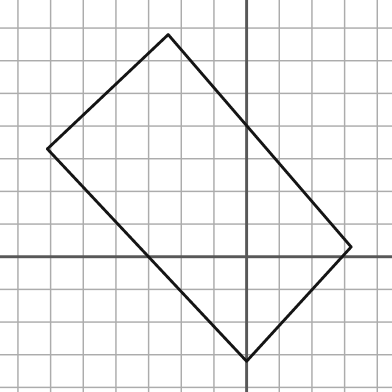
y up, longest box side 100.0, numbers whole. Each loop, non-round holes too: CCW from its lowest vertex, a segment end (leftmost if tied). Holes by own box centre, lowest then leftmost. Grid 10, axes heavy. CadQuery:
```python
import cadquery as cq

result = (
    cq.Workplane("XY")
    .moveTo(0.0, -32.0)
    .lineTo(32.0, 3.0)
    .lineTo(-24.0, 68.0)
    .lineTo(-61.0, 33.0)
    .close()
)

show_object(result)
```